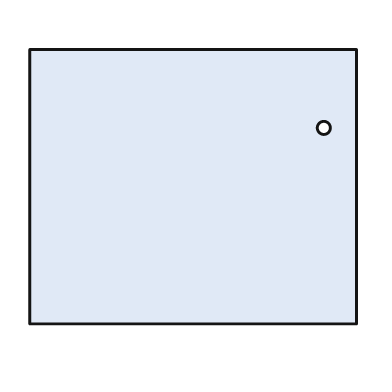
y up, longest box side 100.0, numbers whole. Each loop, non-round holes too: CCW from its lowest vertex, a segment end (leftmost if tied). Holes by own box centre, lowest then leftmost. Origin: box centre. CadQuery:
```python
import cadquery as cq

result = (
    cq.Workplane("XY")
    .moveTo(-50.0, -42.0)
    .lineTo(50.0, -42.0)
    .lineTo(50.0, 42.0)
    .lineTo(-50.0, 42.0)
    .close()
    .moveTo(40.0, 18.0)
    .circle(2.0)
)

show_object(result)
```